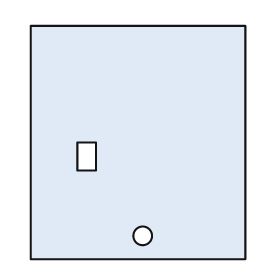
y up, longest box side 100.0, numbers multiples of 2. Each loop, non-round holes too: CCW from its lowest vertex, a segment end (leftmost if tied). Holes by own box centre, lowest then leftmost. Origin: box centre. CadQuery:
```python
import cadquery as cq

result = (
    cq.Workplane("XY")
    .moveTo(-46.0, -50.0)
    .lineTo(46.0, -50.0)
    .lineTo(46.0, 50.0)
    .lineTo(-46.0, 50.0)
    .close()
    .moveTo(2.0, -40.0)
    .circle(4.0)
    .moveTo(-26.0, -12.0)
    .lineTo(-18.0, -12.0)
    .lineTo(-18.0, 0.0)
    .lineTo(-26.0, 0.0)
    .close()
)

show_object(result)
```